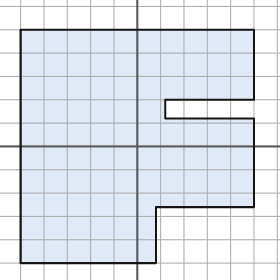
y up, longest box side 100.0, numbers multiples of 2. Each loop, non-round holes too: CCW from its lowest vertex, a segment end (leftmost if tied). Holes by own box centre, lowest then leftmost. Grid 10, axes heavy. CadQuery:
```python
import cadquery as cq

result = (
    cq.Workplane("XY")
    .moveTo(-50.0, -50.0)
    .lineTo(8.0, -50.0)
    .lineTo(8.0, -26.0)
    .lineTo(50.0, -26.0)
    .lineTo(50.0, 12.0)
    .lineTo(12.0, 12.0)
    .lineTo(12.0, 20.0)
    .lineTo(50.0, 20.0)
    .lineTo(50.0, 50.0)
    .lineTo(-50.0, 50.0)
    .close()
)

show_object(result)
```